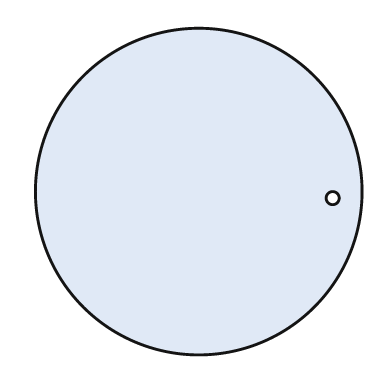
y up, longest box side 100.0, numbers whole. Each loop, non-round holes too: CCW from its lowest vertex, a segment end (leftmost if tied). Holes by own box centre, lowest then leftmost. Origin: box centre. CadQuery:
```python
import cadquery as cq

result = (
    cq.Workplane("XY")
    .moveTo(0.0, 0.0)
    .circle(50.0)
    .moveTo(41.0, -2.0)
    .circle(2.0)
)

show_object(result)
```